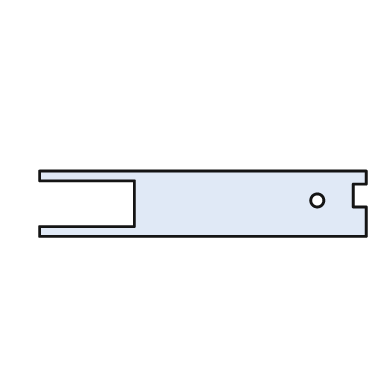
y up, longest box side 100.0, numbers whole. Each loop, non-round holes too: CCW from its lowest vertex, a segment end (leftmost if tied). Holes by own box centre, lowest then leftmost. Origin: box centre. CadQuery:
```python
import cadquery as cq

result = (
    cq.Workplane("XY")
    .moveTo(-50.0, -10.0)
    .lineTo(50.0, -10.0)
    .lineTo(50.0, -1.0)
    .lineTo(46.0, -1.0)
    .lineTo(46.0, 6.0)
    .lineTo(50.0, 6.0)
    .lineTo(50.0, 10.0)
    .lineTo(-50.0, 10.0)
    .lineTo(-50.0, 7.0)
    .lineTo(-21.0, 7.0)
    .lineTo(-21.0, -7.0)
    .lineTo(-50.0, -7.0)
    .close()
    .moveTo(35.0, 1.0)
    .circle(2.0)
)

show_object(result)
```